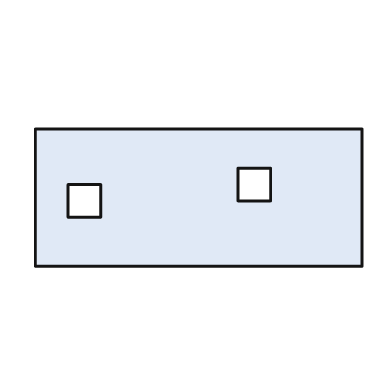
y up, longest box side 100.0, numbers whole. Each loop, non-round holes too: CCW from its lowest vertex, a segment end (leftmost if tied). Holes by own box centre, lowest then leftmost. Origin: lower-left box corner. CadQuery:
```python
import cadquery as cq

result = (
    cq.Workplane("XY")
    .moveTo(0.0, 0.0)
    .lineTo(100.0, 0.0)
    .lineTo(100.0, 42.0)
    .lineTo(0.0, 42.0)
    .close()
    .moveTo(10.0, 15.0)
    .lineTo(20.0, 15.0)
    .lineTo(20.0, 25.0)
    .lineTo(10.0, 25.0)
    .close()
    .moveTo(62.0, 20.0)
    .lineTo(72.0, 20.0)
    .lineTo(72.0, 30.0)
    .lineTo(62.0, 30.0)
    .close()
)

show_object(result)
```